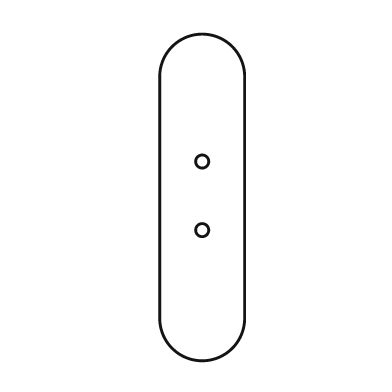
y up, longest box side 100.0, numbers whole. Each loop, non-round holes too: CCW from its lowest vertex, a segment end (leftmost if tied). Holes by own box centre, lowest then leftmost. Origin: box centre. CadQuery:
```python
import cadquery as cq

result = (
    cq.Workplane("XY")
    .moveTo(-13.0, -37.0)
    .threePointArc((0.0, -50.0), (13.0, -37.0))
    .lineTo(13.0, 37.0)
    .threePointArc((0.0, 50.0), (-13.0, 37.0))
    .close()
    .moveTo(0.0, -10.0)
    .circle(2.0)
    .moveTo(0.0, 11.0)
    .circle(2.0)
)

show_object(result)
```